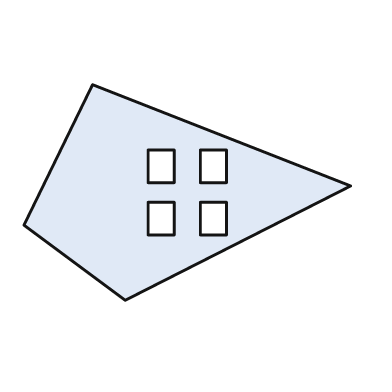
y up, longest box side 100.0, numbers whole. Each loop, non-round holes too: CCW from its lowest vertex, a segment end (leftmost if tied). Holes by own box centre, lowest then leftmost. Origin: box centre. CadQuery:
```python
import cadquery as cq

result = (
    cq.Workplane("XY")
    .moveTo(-19.0, -33.0)
    .lineTo(50.0, 2.0)
    .lineTo(-29.0, 33.0)
    .lineTo(-50.0, -10.0)
    .close()
    .moveTo(-12.0, -13.0)
    .lineTo(-4.0, -13.0)
    .lineTo(-4.0, -3.0)
    .lineTo(-12.0, -3.0)
    .close()
    .moveTo(4.0, -13.0)
    .lineTo(12.0, -13.0)
    .lineTo(12.0, -3.0)
    .lineTo(4.0, -3.0)
    .close()
    .moveTo(-12.0, 3.0)
    .lineTo(-4.0, 3.0)
    .lineTo(-4.0, 13.0)
    .lineTo(-12.0, 13.0)
    .close()
    .moveTo(4.0, 3.0)
    .lineTo(12.0, 3.0)
    .lineTo(12.0, 13.0)
    .lineTo(4.0, 13.0)
    .close()
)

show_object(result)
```